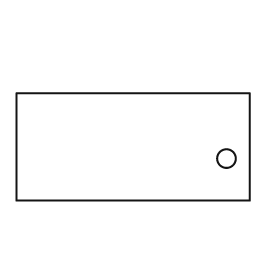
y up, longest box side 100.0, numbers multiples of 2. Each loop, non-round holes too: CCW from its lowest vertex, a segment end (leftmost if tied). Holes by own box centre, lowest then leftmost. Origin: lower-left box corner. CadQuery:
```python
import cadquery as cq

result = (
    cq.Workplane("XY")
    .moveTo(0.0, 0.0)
    .lineTo(100.0, 0.0)
    .lineTo(100.0, 46.0)
    .lineTo(0.0, 46.0)
    .close()
    .moveTo(90.0, 18.0)
    .circle(4.0)
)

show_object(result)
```